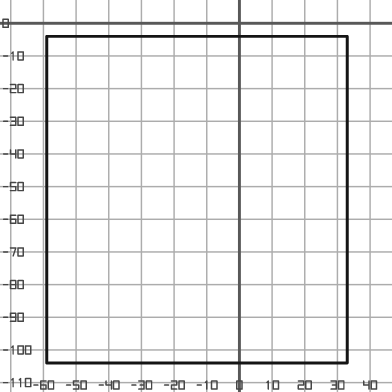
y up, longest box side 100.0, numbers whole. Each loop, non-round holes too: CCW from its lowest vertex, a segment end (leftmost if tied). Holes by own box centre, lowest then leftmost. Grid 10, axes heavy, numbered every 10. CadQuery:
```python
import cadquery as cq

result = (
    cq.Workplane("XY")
    .moveTo(-59.0, -104.0)
    .lineTo(33.0, -104.0)
    .lineTo(33.0, -4.0)
    .lineTo(-59.0, -4.0)
    .close()
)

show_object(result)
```